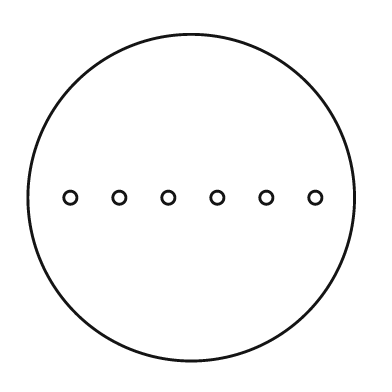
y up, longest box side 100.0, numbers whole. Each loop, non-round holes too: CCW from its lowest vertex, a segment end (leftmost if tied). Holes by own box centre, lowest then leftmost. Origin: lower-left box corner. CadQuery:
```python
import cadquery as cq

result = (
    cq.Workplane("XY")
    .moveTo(50.0, 50.0)
    .circle(50.0)
    .moveTo(13.0, 50.0)
    .circle(2.0)
    .moveTo(28.0, 50.0)
    .circle(2.0)
    .moveTo(43.0, 50.0)
    .circle(2.0)
    .moveTo(58.0, 50.0)
    .circle(2.0)
    .moveTo(73.0, 50.0)
    .circle(2.0)
    .moveTo(88.0, 50.0)
    .circle(2.0)
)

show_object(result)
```